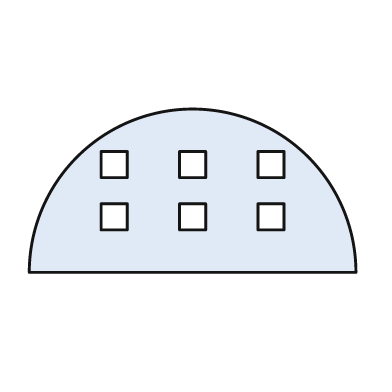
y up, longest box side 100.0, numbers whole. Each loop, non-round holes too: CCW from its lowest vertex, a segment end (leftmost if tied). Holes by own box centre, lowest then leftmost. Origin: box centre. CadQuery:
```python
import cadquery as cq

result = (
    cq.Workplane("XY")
    .moveTo(-50.0, -25.0)
    .lineTo(50.0, -25.0)
    .threePointArc((0.0, 25.0), (-50.0, -25.0))
    .close()
    .moveTo(-28.0, -12.0)
    .lineTo(-20.0, -12.0)
    .lineTo(-20.0, -4.0)
    .lineTo(-28.0, -4.0)
    .close()
    .moveTo(-4.0, -12.0)
    .lineTo(4.0, -12.0)
    .lineTo(4.0, -4.0)
    .lineTo(-4.0, -4.0)
    .close()
    .moveTo(20.0, -12.0)
    .lineTo(28.0, -12.0)
    .lineTo(28.0, -4.0)
    .lineTo(20.0, -4.0)
    .close()
    .moveTo(-28.0, 4.0)
    .lineTo(-20.0, 4.0)
    .lineTo(-20.0, 12.0)
    .lineTo(-28.0, 12.0)
    .close()
    .moveTo(-4.0, 4.0)
    .lineTo(4.0, 4.0)
    .lineTo(4.0, 12.0)
    .lineTo(-4.0, 12.0)
    .close()
    .moveTo(20.0, 4.0)
    .lineTo(28.0, 4.0)
    .lineTo(28.0, 12.0)
    .lineTo(20.0, 12.0)
    .close()
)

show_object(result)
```